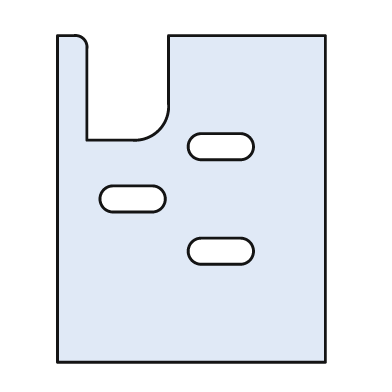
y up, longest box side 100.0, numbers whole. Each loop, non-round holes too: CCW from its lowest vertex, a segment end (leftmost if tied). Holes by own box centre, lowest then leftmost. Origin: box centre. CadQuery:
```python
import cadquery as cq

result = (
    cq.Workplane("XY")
    .moveTo(-41.0, -50.0)
    .lineTo(41.0, -50.0)
    .lineTo(41.0, 50.0)
    .lineTo(-7.0, 50.0)
    .lineTo(-7.0, 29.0)
    .threePointArc((-10.0, 21.0), (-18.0, 18.0))
    .lineTo(-32.0, 18.0)
    .lineTo(-32.0, 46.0)
    .threePointArc((-33.0, 49.0), (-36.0, 50.0))
    .lineTo(-41.0, 50.0)
    .close()
    .moveTo(3.0, -20.0)
    .lineTo(15.0, -20.0)
    .threePointArc((19.0, -16.0), (15.0, -12.0))
    .lineTo(3.0, -12.0)
    .threePointArc((-1.0, -16.0), (3.0, -20.0))
    .close()
    .moveTo(-24.0, -4.0)
    .lineTo(-12.0, -4.0)
    .threePointArc((-8.0, 0.0), (-12.0, 4.0))
    .lineTo(-24.0, 4.0)
    .threePointArc((-28.0, 0.0), (-24.0, -4.0))
    .close()
    .moveTo(3.0, 12.0)
    .lineTo(15.0, 12.0)
    .threePointArc((19.0, 16.0), (15.0, 20.0))
    .lineTo(3.0, 20.0)
    .threePointArc((-1.0, 16.0), (3.0, 12.0))
    .close()
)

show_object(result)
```